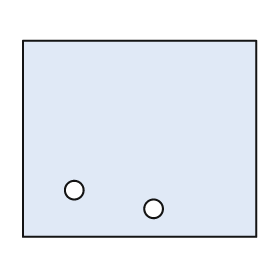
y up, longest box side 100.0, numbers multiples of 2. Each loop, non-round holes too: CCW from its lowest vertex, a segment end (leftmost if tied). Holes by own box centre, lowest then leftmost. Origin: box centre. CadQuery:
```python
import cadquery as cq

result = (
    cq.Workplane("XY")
    .moveTo(-50.0, -42.0)
    .lineTo(50.0, -42.0)
    .lineTo(50.0, 42.0)
    .lineTo(-50.0, 42.0)
    .close()
    .moveTo(6.0, -30.0)
    .circle(4.0)
    .moveTo(-28.0, -22.0)
    .circle(4.0)
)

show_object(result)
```